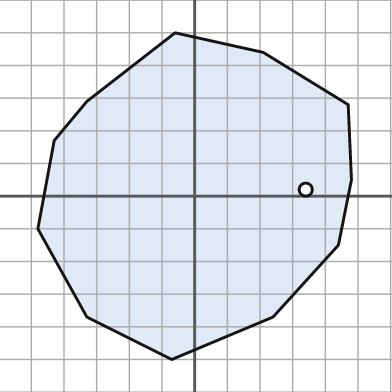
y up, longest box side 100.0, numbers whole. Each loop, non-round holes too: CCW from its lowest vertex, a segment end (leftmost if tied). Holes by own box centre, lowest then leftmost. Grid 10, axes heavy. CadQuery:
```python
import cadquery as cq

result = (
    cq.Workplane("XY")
    .moveTo(-7.0, -50.0)
    .lineTo(24.0, -37.0)
    .lineTo(44.0, -15.0)
    .lineTo(48.0, 5.0)
    .lineTo(47.0, 28.0)
    .lineTo(21.0, 44.0)
    .lineTo(-6.0, 50.0)
    .lineTo(-33.0, 29.0)
    .lineTo(-43.0, 17.0)
    .lineTo(-48.0, -10.0)
    .lineTo(-33.0, -37.0)
    .close()
    .moveTo(34.0, 2.0)
    .circle(2.0)
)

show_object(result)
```